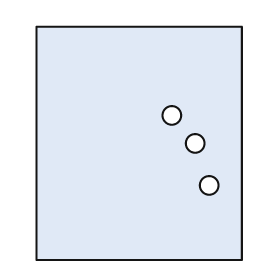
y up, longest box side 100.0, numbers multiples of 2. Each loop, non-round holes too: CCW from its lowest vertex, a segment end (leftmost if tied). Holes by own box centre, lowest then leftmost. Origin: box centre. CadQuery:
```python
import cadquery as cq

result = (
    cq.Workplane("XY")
    .moveTo(-44.0, -50.0)
    .lineTo(44.0, -50.0)
    .lineTo(44.0, 50.0)
    .lineTo(-44.0, 50.0)
    .close()
    .moveTo(30.0, -18.0)
    .circle(4.0)
    .moveTo(24.0, 0.0)
    .circle(4.0)
    .moveTo(14.0, 12.0)
    .circle(4.0)
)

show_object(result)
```